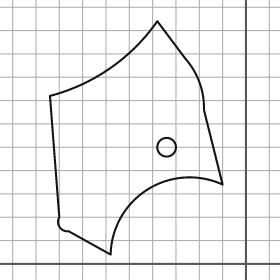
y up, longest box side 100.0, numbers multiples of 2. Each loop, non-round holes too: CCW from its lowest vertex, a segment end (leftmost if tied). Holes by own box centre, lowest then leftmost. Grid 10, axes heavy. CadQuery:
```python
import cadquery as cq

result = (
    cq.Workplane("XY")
    .moveTo(-58.0, 4.0)
    .threePointArc((-42.0, 32.0), (-10.0, 34.0))
    .lineTo(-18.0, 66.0)
    .threePointArc((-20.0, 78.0), (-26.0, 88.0))
    .lineTo(-38.0, 104.0)
    .threePointArc((-58.0, 84.0), (-84.0, 72.0))
    .lineTo(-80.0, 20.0)
    .threePointArc((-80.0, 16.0), (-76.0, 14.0))
    .close()
    .moveTo(-34.0, 50.0)
    .circle(4.0)
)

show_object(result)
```